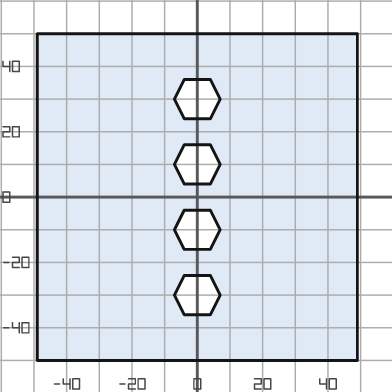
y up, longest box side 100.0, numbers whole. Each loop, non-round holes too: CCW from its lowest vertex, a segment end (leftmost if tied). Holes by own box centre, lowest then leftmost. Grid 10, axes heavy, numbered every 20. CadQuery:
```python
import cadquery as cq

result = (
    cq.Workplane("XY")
    .moveTo(-49.0, -50.0)
    .lineTo(49.0, -50.0)
    .lineTo(49.0, 50.0)
    .lineTo(-49.0, 50.0)
    .close()
    .moveTo(-4.0, -36.0)
    .lineTo(4.0, -36.0)
    .lineTo(7.0, -30.0)
    .lineTo(4.0, -24.0)
    .lineTo(-4.0, -24.0)
    .lineTo(-7.0, -30.0)
    .close()
    .moveTo(-4.0, -16.0)
    .lineTo(4.0, -16.0)
    .lineTo(7.0, -10.0)
    .lineTo(4.0, -4.0)
    .lineTo(-4.0, -4.0)
    .lineTo(-7.0, -10.0)
    .close()
    .moveTo(-4.0, 4.0)
    .lineTo(4.0, 4.0)
    .lineTo(7.0, 10.0)
    .lineTo(4.0, 16.0)
    .lineTo(-4.0, 16.0)
    .lineTo(-7.0, 10.0)
    .close()
    .moveTo(-4.0, 24.0)
    .lineTo(4.0, 24.0)
    .lineTo(7.0, 30.0)
    .lineTo(4.0, 36.0)
    .lineTo(-4.0, 36.0)
    .lineTo(-7.0, 30.0)
    .close()
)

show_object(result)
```